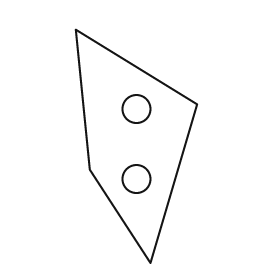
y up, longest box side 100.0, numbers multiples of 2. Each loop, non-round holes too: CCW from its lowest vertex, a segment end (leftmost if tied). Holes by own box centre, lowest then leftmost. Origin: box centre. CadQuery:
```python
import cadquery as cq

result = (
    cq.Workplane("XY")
    .moveTo(6.0, -50.0)
    .lineTo(26.0, 18.0)
    .lineTo(-26.0, 50.0)
    .lineTo(-20.0, -10.0)
    .close()
    .moveTo(0.0, -14.0)
    .circle(6.0)
    .moveTo(0.0, 16.0)
    .circle(6.0)
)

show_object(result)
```